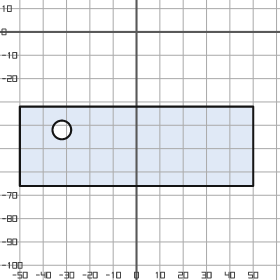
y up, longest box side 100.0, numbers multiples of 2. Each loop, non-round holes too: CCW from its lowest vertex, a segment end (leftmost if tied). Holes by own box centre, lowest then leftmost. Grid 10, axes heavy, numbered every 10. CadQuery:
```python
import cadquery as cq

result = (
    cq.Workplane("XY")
    .moveTo(-50.0, -66.0)
    .lineTo(50.0, -66.0)
    .lineTo(50.0, -32.0)
    .lineTo(-50.0, -32.0)
    .close()
    .moveTo(-32.0, -42.0)
    .circle(4.0)
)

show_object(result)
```